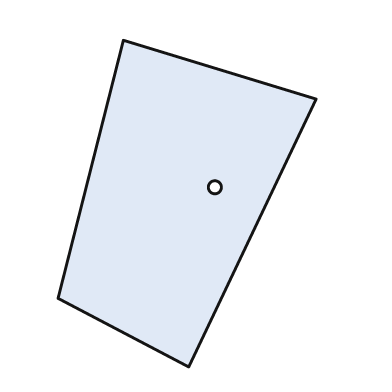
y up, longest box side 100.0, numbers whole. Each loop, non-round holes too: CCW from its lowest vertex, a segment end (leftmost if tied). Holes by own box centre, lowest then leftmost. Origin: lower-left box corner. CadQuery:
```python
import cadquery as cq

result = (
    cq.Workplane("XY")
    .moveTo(40.0, 0.0)
    .lineTo(79.0, 82.0)
    .lineTo(20.0, 100.0)
    .lineTo(0.0, 21.0)
    .close()
    .moveTo(48.0, 55.0)
    .circle(2.0)
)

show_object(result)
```